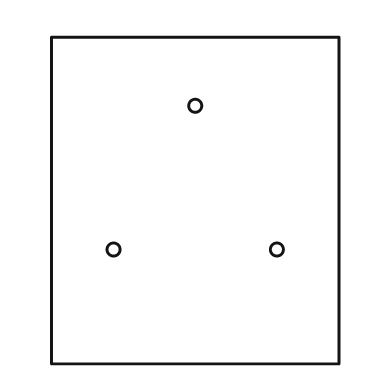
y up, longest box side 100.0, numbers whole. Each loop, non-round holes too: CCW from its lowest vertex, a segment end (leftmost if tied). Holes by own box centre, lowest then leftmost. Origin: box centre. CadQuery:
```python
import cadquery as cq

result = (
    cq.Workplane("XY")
    .moveTo(-44.0, -50.0)
    .lineTo(44.0, -50.0)
    .lineTo(44.0, 50.0)
    .lineTo(-44.0, 50.0)
    .close()
    .moveTo(-25.0, -15.0)
    .circle(2.0)
    .moveTo(25.0, -15.0)
    .circle(2.0)
    .moveTo(0.0, 29.0)
    .circle(2.0)
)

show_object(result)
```